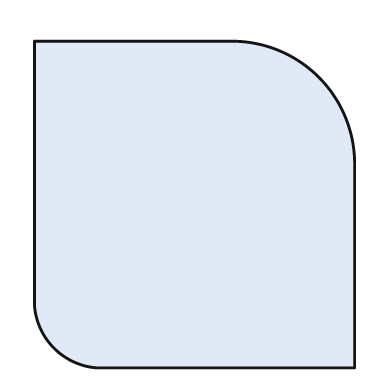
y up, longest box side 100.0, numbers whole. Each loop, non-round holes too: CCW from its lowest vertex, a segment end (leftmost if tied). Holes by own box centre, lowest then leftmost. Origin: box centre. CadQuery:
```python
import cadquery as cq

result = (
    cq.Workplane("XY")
    .moveTo(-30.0, -50.0)
    .lineTo(49.0, -50.0)
    .lineTo(49.0, 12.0)
    .threePointArc((38.0, 39.0), (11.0, 50.0))
    .lineTo(-49.0, 50.0)
    .lineTo(-49.0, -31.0)
    .threePointArc((-43.0, -44.0), (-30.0, -50.0))
    .close()
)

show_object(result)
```